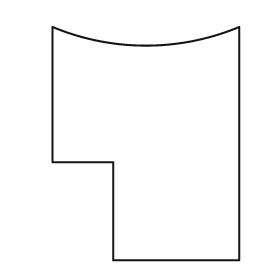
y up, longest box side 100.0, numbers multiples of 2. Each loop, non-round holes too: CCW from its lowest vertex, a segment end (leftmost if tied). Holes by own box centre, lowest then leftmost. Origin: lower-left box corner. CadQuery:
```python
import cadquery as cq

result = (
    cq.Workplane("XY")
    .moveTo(26.0, 0.0)
    .lineTo(80.0, 0.0)
    .lineTo(80.0, 100.0)
    .threePointArc((40.0, 92.0), (0.0, 100.0))
    .lineTo(0.0, 42.0)
    .lineTo(26.0, 42.0)
    .close()
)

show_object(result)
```